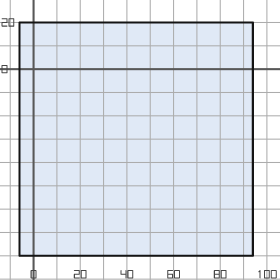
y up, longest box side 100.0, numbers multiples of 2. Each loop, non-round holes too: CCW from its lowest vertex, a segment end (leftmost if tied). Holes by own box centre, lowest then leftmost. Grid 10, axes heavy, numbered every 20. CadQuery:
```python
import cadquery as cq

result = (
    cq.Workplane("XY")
    .moveTo(-6.0, -80.0)
    .lineTo(94.0, -80.0)
    .lineTo(94.0, 20.0)
    .lineTo(-6.0, 20.0)
    .close()
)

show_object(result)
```